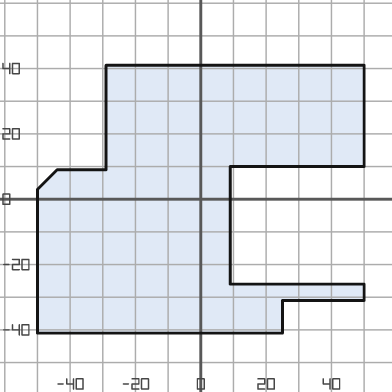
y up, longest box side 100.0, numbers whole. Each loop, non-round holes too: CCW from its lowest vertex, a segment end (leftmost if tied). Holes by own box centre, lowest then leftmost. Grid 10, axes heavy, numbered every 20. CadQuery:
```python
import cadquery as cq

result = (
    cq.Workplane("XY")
    .moveTo(-50.0, -41.0)
    .lineTo(25.0, -41.0)
    .lineTo(25.0, -31.0)
    .lineTo(50.0, -31.0)
    .lineTo(50.0, -26.0)
    .lineTo(9.0, -26.0)
    .lineTo(9.0, 10.0)
    .lineTo(50.0, 10.0)
    .lineTo(50.0, 41.0)
    .lineTo(-29.0, 41.0)
    .lineTo(-29.0, 9.0)
    .lineTo(-44.0, 9.0)
    .lineTo(-50.0, 3.0)
    .close()
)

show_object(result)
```